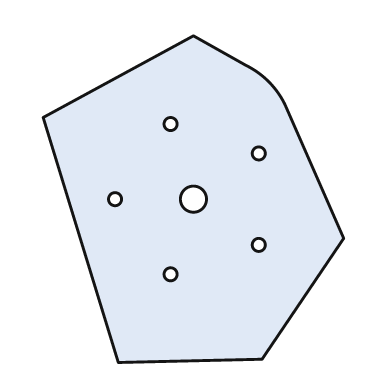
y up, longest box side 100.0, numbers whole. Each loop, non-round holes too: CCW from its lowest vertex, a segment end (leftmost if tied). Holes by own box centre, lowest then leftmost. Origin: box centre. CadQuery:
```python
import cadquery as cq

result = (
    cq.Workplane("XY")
    .moveTo(-23.0, -50.0)
    .lineTo(21.0, -49.0)
    .lineTo(46.0, -12.0)
    .lineTo(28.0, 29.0)
    .threePointArc((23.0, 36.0), (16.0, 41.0))
    .lineTo(0.0, 50.0)
    .lineTo(-46.0, 25.0)
    .close()
    .moveTo(-7.0, -23.0)
    .circle(2.0)
    .moveTo(20.0, -14.0)
    .circle(2.0)
    .moveTo(-24.0, 0.0)
    .circle(2.0)
    .moveTo(0.0, 0.0)
    .circle(4.0)
    .moveTo(20.0, 14.0)
    .circle(2.0)
    .moveTo(-7.0, 23.0)
    .circle(2.0)
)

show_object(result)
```